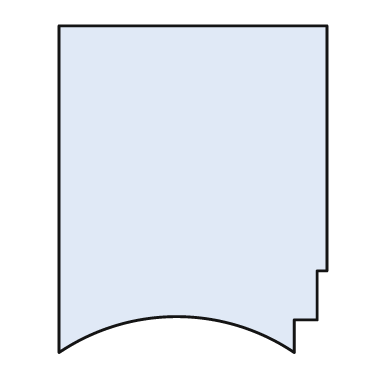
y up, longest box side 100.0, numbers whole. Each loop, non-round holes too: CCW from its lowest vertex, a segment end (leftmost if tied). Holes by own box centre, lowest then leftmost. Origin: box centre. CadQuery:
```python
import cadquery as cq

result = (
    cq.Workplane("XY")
    .moveTo(-41.0, -50.0)
    .threePointArc((-5.0, -39.0), (31.0, -50.0))
    .lineTo(31.0, -40.0)
    .lineTo(38.0, -40.0)
    .lineTo(38.0, -25.0)
    .lineTo(41.0, -25.0)
    .lineTo(41.0, 50.0)
    .lineTo(-41.0, 50.0)
    .close()
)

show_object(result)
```